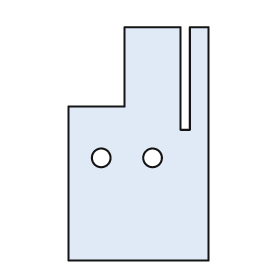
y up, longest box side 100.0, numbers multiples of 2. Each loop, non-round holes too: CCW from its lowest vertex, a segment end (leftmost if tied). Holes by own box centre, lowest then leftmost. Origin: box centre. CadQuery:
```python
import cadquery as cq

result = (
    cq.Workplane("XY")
    .moveTo(-30.0, -50.0)
    .lineTo(30.0, -50.0)
    .lineTo(30.0, 50.0)
    .lineTo(22.0, 50.0)
    .lineTo(22.0, 6.0)
    .lineTo(18.0, 6.0)
    .lineTo(18.0, 50.0)
    .lineTo(-6.0, 50.0)
    .lineTo(-6.0, 16.0)
    .lineTo(-30.0, 16.0)
    .close()
    .moveTo(-16.0, -6.0)
    .circle(4.0)
    .moveTo(6.0, -6.0)
    .circle(4.0)
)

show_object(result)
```